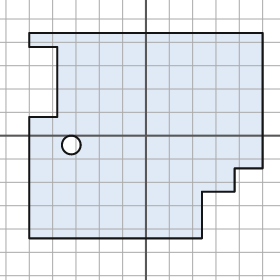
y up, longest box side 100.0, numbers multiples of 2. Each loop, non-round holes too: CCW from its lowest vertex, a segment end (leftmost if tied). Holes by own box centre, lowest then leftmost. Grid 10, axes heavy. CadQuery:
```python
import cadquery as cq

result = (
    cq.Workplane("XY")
    .moveTo(-50.0, -44.0)
    .lineTo(24.0, -44.0)
    .lineTo(24.0, -24.0)
    .lineTo(38.0, -24.0)
    .lineTo(38.0, -14.0)
    .lineTo(50.0, -14.0)
    .lineTo(50.0, 44.0)
    .lineTo(-50.0, 44.0)
    .lineTo(-50.0, 38.0)
    .lineTo(-38.0, 38.0)
    .lineTo(-38.0, 8.0)
    .lineTo(-50.0, 8.0)
    .close()
    .moveTo(-32.0, -4.0)
    .circle(4.0)
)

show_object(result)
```